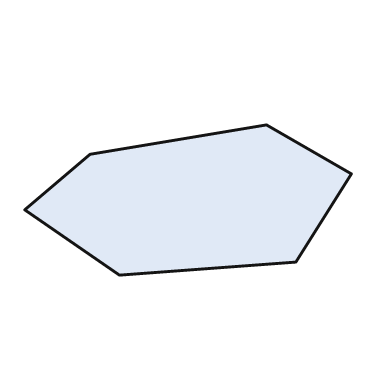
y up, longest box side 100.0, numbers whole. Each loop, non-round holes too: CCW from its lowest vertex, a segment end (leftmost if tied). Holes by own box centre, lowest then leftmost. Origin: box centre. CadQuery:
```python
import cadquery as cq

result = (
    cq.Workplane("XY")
    .moveTo(-21.0, -23.0)
    .lineTo(33.0, -19.0)
    .lineTo(50.0, 8.0)
    .lineTo(24.0, 23.0)
    .lineTo(-30.0, 14.0)
    .lineTo(-50.0, -3.0)
    .close()
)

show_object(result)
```